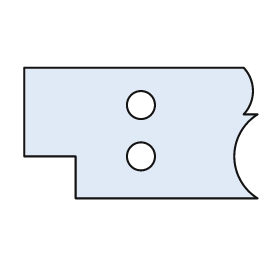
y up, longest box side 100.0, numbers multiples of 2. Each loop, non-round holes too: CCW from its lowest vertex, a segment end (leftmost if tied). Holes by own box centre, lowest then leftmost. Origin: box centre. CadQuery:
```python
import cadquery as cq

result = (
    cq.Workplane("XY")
    .moveTo(-28.0, -28.0)
    .lineTo(50.0, -28.0)
    .threePointArc((40.0, -10.0), (50.0, 8.0))
    .lineTo(44.0, 8.0)
    .threePointArc((48.0, 18.0), (44.0, 28.0))
    .lineTo(-50.0, 28.0)
    .lineTo(-50.0, -10.0)
    .lineTo(-28.0, -10.0)
    .close()
    .moveTo(0.0, -10.0)
    .circle(6.0)
    .moveTo(0.0, 12.0)
    .circle(6.0)
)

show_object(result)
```